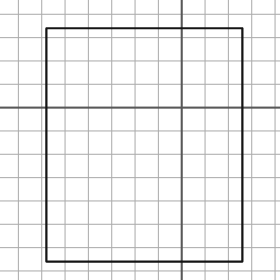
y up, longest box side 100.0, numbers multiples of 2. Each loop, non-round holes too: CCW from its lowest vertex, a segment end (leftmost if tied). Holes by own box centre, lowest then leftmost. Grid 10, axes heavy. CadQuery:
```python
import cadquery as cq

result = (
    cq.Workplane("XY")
    .moveTo(-58.0, -66.0)
    .lineTo(26.0, -66.0)
    .lineTo(26.0, 34.0)
    .lineTo(-58.0, 34.0)
    .close()
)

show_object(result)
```